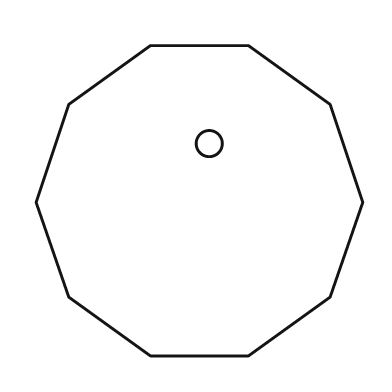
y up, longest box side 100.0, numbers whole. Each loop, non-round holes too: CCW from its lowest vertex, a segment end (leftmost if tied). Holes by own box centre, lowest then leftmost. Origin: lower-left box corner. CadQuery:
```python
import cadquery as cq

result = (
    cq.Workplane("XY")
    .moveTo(35.0, 0.0)
    .lineTo(65.0, 0.0)
    .lineTo(90.0, 18.0)
    .lineTo(100.0, 47.0)
    .lineTo(90.0, 77.0)
    .lineTo(65.0, 95.0)
    .lineTo(35.0, 95.0)
    .lineTo(10.0, 77.0)
    .lineTo(0.0, 47.0)
    .lineTo(10.0, 18.0)
    .close()
    .moveTo(53.0, 65.0)
    .circle(4.0)
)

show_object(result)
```